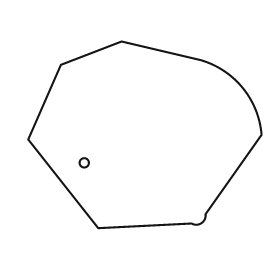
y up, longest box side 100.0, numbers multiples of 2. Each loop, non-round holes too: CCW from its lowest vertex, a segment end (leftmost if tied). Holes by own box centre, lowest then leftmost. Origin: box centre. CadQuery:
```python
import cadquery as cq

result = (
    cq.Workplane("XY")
    .moveTo(-20.0, -40.0)
    .lineTo(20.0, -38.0)
    .threePointArc((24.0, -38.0), (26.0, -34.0))
    .lineTo(50.0, 0.0)
    .threePointArc((42.0, 20.0), (24.0, 32.0))
    .lineTo(-10.0, 40.0)
    .lineTo(-36.0, 30.0)
    .lineTo(-50.0, -2.0)
    .close()
    .moveTo(-26.0, -12.0)
    .circle(2.0)
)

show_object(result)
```